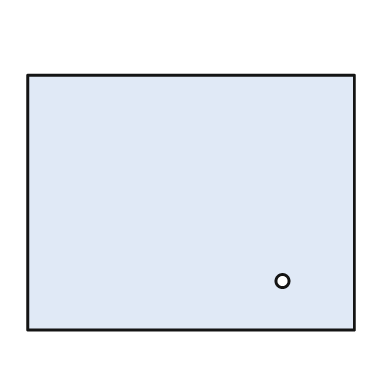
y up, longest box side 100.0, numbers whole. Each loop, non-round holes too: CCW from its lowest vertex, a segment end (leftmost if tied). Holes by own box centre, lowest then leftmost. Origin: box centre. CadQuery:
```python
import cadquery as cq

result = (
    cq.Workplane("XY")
    .moveTo(-50.0, -39.0)
    .lineTo(50.0, -39.0)
    .lineTo(50.0, 39.0)
    .lineTo(-50.0, 39.0)
    .close()
    .moveTo(28.0, -24.0)
    .circle(2.0)
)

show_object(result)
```